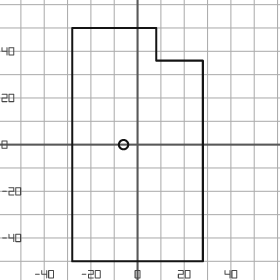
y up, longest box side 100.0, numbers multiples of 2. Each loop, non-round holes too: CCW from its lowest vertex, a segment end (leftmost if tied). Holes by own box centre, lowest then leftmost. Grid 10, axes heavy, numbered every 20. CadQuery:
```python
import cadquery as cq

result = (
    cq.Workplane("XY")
    .moveTo(-28.0, -50.0)
    .lineTo(28.0, -50.0)
    .lineTo(28.0, 36.0)
    .lineTo(8.0, 36.0)
    .lineTo(8.0, 50.0)
    .lineTo(-28.0, 50.0)
    .close()
    .moveTo(-6.0, 0.0)
    .circle(2.0)
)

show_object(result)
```